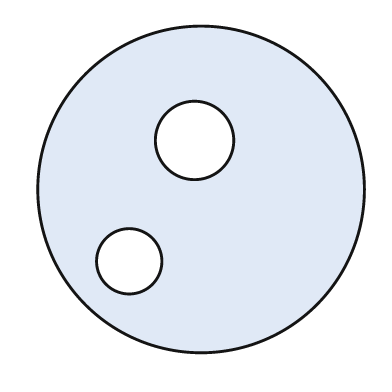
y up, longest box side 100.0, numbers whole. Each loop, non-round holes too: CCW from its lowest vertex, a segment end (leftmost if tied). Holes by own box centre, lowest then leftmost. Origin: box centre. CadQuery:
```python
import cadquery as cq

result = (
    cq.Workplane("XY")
    .moveTo(0.0, 0.0)
    .circle(50.0)
    .moveTo(-22.0, -22.0)
    .circle(10.0)
    .moveTo(-2.0, 15.0)
    .circle(12.0)
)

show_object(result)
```